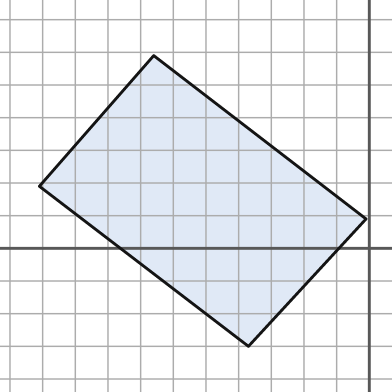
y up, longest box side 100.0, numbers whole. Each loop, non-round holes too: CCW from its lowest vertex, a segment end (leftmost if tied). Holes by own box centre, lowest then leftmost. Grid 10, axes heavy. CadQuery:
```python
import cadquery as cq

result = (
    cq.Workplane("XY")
    .moveTo(-37.0, -30.0)
    .lineTo(-1.0, 9.0)
    .lineTo(-66.0, 59.0)
    .lineTo(-101.0, 19.0)
    .close()
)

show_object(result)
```